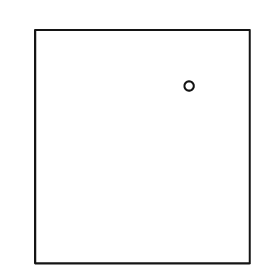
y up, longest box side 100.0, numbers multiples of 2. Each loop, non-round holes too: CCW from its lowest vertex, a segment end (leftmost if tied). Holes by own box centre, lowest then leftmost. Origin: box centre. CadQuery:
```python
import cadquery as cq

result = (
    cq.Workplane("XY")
    .moveTo(-46.0, -50.0)
    .lineTo(46.0, -50.0)
    .lineTo(46.0, 50.0)
    .lineTo(-46.0, 50.0)
    .close()
    .moveTo(20.0, 26.0)
    .circle(2.0)
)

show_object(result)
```